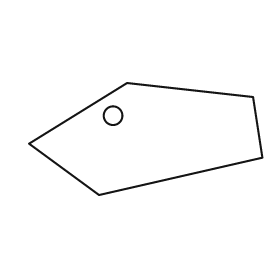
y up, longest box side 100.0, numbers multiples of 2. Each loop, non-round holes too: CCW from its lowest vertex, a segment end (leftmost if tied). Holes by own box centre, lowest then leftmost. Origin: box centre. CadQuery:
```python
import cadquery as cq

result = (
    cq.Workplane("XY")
    .moveTo(-20.0, -24.0)
    .lineTo(50.0, -8.0)
    .lineTo(46.0, 18.0)
    .lineTo(-8.0, 24.0)
    .lineTo(-50.0, -2.0)
    .close()
    .moveTo(-14.0, 10.0)
    .circle(4.0)
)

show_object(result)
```